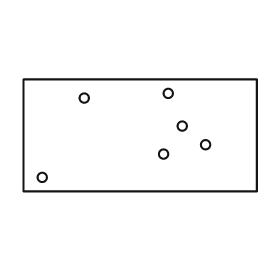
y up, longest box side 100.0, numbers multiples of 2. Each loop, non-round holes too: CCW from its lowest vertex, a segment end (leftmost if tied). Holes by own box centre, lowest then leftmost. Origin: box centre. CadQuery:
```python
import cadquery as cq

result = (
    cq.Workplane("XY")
    .moveTo(-50.0, -24.0)
    .lineTo(50.0, -24.0)
    .lineTo(50.0, 24.0)
    .lineTo(-50.0, 24.0)
    .close()
    .moveTo(-42.0, -18.0)
    .circle(2.0)
    .moveTo(10.0, -8.0)
    .circle(2.0)
    .moveTo(28.0, -4.0)
    .circle(2.0)
    .moveTo(18.0, 4.0)
    .circle(2.0)
    .moveTo(-24.0, 16.0)
    .circle(2.0)
    .moveTo(12.0, 18.0)
    .circle(2.0)
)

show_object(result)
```